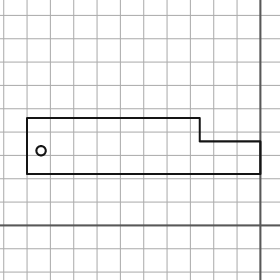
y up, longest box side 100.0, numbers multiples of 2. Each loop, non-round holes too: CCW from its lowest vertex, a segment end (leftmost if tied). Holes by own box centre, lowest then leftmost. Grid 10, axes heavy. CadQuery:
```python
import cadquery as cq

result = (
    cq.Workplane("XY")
    .moveTo(-100.0, 22.0)
    .lineTo(0.0, 22.0)
    .lineTo(0.0, 36.0)
    .lineTo(-26.0, 36.0)
    .lineTo(-26.0, 46.0)
    .lineTo(-100.0, 46.0)
    .close()
    .moveTo(-94.0, 32.0)
    .circle(2.0)
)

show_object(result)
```